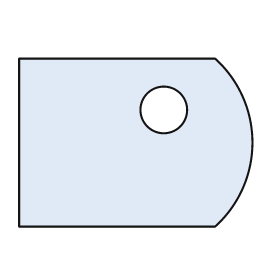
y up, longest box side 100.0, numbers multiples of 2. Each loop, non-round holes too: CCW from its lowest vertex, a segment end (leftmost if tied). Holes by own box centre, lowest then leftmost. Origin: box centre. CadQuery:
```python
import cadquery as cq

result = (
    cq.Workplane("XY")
    .moveTo(-50.0, -36.0)
    .lineTo(34.0, -36.0)
    .threePointArc((50.0, 0.0), (34.0, 36.0))
    .lineTo(-50.0, 36.0)
    .close()
    .moveTo(12.0, 14.0)
    .circle(10.0)
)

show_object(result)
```